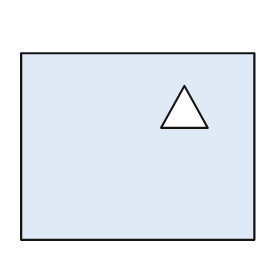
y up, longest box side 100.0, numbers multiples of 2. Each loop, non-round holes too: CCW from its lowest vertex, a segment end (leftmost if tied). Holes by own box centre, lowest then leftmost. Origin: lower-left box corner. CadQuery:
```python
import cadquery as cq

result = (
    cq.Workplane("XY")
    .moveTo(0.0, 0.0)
    .lineTo(100.0, 0.0)
    .lineTo(100.0, 80.0)
    .lineTo(0.0, 80.0)
    .close()
    .moveTo(60.0, 48.0)
    .lineTo(80.0, 48.0)
    .lineTo(70.0, 66.0)
    .close()
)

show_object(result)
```